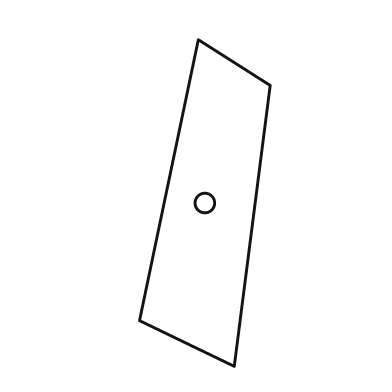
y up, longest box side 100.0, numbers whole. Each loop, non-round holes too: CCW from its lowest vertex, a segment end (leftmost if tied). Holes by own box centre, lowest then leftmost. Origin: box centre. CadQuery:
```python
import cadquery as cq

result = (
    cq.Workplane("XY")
    .moveTo(9.0, -50.0)
    .lineTo(20.0, 36.0)
    .lineTo(-2.0, 50.0)
    .lineTo(-20.0, -36.0)
    .close()
    .moveTo(0.0, 0.0)
    .circle(3.0)
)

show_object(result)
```